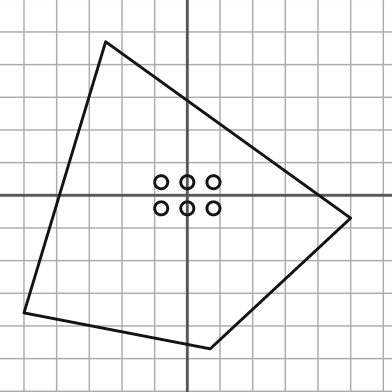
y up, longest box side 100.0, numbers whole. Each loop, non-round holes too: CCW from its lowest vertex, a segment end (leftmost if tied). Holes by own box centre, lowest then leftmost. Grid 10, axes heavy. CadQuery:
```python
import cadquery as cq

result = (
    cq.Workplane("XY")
    .moveTo(7.0, -47.0)
    .lineTo(50.0, -7.0)
    .lineTo(-25.0, 47.0)
    .lineTo(-50.0, -36.0)
    .close()
    .moveTo(-8.0, -4.0)
    .circle(2.0)
    .moveTo(0.0, -4.0)
    .circle(2.0)
    .moveTo(8.0, -4.0)
    .circle(2.0)
    .moveTo(-8.0, 4.0)
    .circle(2.0)
    .moveTo(0.0, 4.0)
    .circle(2.0)
    .moveTo(8.0, 4.0)
    .circle(2.0)
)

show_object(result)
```